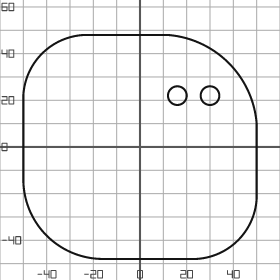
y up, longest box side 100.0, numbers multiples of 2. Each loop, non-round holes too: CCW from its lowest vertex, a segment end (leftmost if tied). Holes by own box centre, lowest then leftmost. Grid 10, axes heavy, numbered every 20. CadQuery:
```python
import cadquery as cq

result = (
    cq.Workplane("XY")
    .moveTo(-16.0, -48.0)
    .lineTo(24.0, -48.0)
    .threePointArc((42.0, -40.0), (50.0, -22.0))
    .lineTo(50.0, 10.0)
    .threePointArc((38.0, 36.0), (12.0, 48.0))
    .lineTo(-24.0, 48.0)
    .threePointArc((-42.0, 40.0), (-50.0, 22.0))
    .lineTo(-50.0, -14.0)
    .threePointArc((-40.0, -38.0), (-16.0, -48.0))
    .close()
    .moveTo(16.0, 22.0)
    .circle(4.0)
    .moveTo(30.0, 22.0)
    .circle(4.0)
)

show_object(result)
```